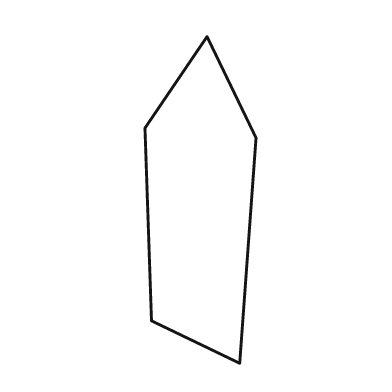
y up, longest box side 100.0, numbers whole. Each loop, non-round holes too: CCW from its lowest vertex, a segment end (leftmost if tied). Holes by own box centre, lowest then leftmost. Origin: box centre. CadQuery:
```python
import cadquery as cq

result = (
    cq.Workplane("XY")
    .moveTo(12.0, -50.0)
    .lineTo(17.0, 19.0)
    .lineTo(2.0, 50.0)
    .lineTo(-17.0, 22.0)
    .lineTo(-15.0, -37.0)
    .close()
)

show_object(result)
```